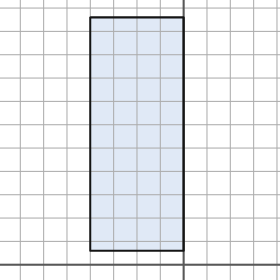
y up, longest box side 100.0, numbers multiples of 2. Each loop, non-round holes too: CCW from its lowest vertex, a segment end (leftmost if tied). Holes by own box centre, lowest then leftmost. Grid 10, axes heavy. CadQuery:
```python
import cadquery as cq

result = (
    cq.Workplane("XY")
    .moveTo(-40.0, 6.0)
    .lineTo(0.0, 6.0)
    .lineTo(0.0, 106.0)
    .lineTo(-40.0, 106.0)
    .close()
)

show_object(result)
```